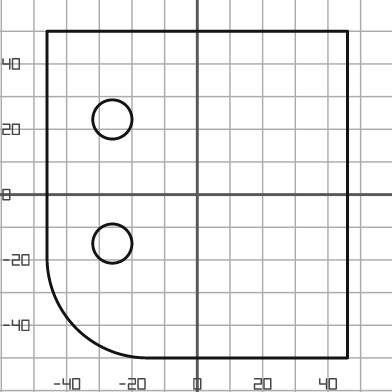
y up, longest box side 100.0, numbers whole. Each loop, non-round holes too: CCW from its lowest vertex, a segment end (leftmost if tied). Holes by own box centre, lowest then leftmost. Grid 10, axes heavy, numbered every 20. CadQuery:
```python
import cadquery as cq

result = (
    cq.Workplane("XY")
    .moveTo(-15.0, -50.0)
    .lineTo(46.0, -50.0)
    .lineTo(46.0, 50.0)
    .lineTo(-46.0, 50.0)
    .lineTo(-46.0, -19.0)
    .threePointArc((-37.0, -41.0), (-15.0, -50.0))
    .close()
    .moveTo(-26.0, -15.0)
    .circle(6.0)
    .moveTo(-26.0, 23.0)
    .circle(6.0)
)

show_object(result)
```